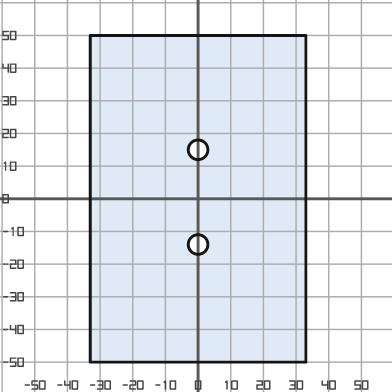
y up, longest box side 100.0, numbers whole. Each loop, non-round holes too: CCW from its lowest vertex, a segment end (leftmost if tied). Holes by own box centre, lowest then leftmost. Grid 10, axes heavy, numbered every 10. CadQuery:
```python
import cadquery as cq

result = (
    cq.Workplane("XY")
    .moveTo(-33.0, -50.0)
    .lineTo(33.0, -50.0)
    .lineTo(33.0, 50.0)
    .lineTo(-33.0, 50.0)
    .close()
    .moveTo(0.0, -14.0)
    .circle(3.0)
    .moveTo(0.0, 15.0)
    .circle(3.0)
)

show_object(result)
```